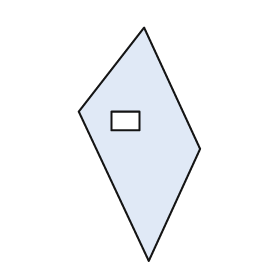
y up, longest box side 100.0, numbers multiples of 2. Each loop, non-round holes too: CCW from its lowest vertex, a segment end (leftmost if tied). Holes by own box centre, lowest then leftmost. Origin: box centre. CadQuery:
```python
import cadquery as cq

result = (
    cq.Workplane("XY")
    .moveTo(4.0, -50.0)
    .lineTo(26.0, -2.0)
    .lineTo(2.0, 50.0)
    .lineTo(-26.0, 14.0)
    .close()
    .moveTo(-12.0, 6.0)
    .lineTo(0.0, 6.0)
    .lineTo(0.0, 14.0)
    .lineTo(-12.0, 14.0)
    .close()
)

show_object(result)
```